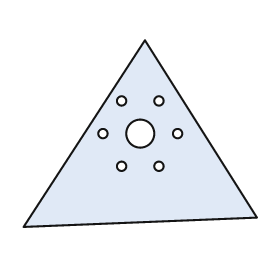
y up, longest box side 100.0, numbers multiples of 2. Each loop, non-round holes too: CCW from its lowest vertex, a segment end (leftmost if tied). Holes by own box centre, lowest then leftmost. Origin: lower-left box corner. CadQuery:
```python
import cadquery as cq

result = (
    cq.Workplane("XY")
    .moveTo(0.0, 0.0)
    .lineTo(100.0, 4.0)
    .lineTo(52.0, 80.0)
    .close()
    .moveTo(42.0, 26.0)
    .circle(2.0)
    .moveTo(58.0, 26.0)
    .circle(2.0)
    .moveTo(34.0, 40.0)
    .circle(2.0)
    .moveTo(50.0, 40.0)
    .circle(6.0)
    .moveTo(66.0, 40.0)
    .circle(2.0)
    .moveTo(42.0, 54.0)
    .circle(2.0)
    .moveTo(58.0, 54.0)
    .circle(2.0)
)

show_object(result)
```